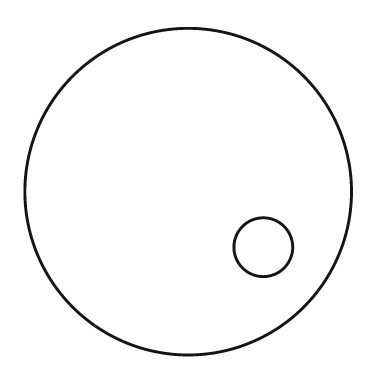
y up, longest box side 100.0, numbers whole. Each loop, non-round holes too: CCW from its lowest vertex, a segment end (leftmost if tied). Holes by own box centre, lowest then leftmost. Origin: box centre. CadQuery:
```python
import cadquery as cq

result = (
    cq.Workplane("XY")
    .moveTo(0.0, 0.0)
    .circle(50.0)
    .moveTo(23.0, -17.0)
    .circle(9.0)
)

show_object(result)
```